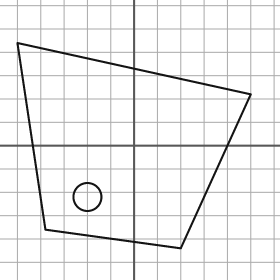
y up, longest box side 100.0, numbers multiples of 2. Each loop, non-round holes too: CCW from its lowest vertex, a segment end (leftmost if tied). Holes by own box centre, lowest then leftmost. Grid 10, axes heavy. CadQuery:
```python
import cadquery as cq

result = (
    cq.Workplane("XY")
    .moveTo(20.0, -44.0)
    .lineTo(50.0, 22.0)
    .lineTo(-50.0, 44.0)
    .lineTo(-38.0, -36.0)
    .close()
    .moveTo(-20.0, -22.0)
    .circle(6.0)
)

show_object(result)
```